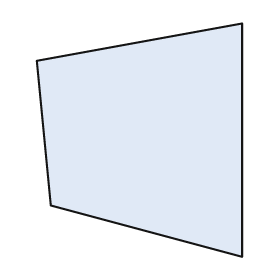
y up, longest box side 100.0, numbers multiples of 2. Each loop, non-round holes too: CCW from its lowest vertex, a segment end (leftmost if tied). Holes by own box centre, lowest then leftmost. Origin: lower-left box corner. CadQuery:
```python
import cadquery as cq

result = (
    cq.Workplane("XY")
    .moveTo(88.0, 0.0)
    .lineTo(88.0, 100.0)
    .lineTo(0.0, 84.0)
    .lineTo(6.0, 22.0)
    .close()
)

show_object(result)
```